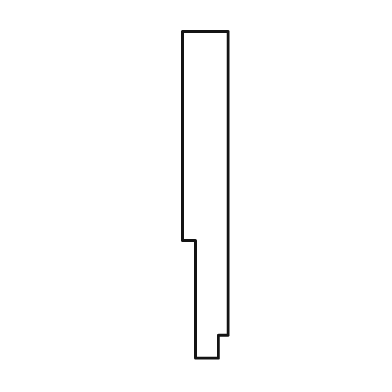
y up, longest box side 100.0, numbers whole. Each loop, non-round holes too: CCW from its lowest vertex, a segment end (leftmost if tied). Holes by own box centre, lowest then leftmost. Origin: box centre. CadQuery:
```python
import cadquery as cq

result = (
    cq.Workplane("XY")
    .moveTo(-3.0, -50.0)
    .lineTo(4.0, -50.0)
    .lineTo(4.0, -43.0)
    .lineTo(7.0, -43.0)
    .lineTo(7.0, 50.0)
    .lineTo(-7.0, 50.0)
    .lineTo(-7.0, -14.0)
    .lineTo(-3.0, -14.0)
    .close()
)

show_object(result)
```